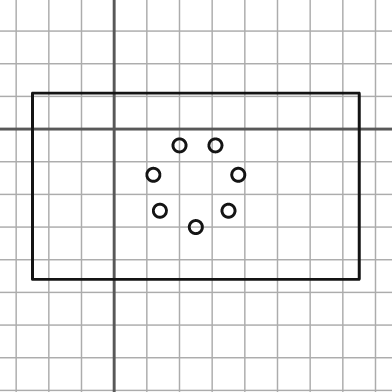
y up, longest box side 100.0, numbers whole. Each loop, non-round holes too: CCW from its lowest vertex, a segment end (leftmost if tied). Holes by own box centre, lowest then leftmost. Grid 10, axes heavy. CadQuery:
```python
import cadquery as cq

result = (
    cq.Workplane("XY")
    .moveTo(-25.0, -46.0)
    .lineTo(75.0, -46.0)
    .lineTo(75.0, 11.0)
    .lineTo(-25.0, 11.0)
    .close()
    .moveTo(25.0, -30.0)
    .circle(2.0)
    .moveTo(14.0, -25.0)
    .circle(2.0)
    .moveTo(35.0, -25.0)
    .circle(2.0)
    .moveTo(12.0, -14.0)
    .circle(2.0)
    .moveTo(38.0, -14.0)
    .circle(2.0)
    .moveTo(20.0, -5.0)
    .circle(2.0)
    .moveTo(31.0, -5.0)
    .circle(2.0)
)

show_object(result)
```